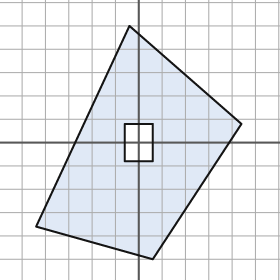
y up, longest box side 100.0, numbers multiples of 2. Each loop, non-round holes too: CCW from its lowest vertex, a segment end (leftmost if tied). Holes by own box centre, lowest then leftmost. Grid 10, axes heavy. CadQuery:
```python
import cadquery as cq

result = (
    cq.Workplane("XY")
    .moveTo(6.0, -50.0)
    .lineTo(44.0, 8.0)
    .lineTo(-4.0, 50.0)
    .lineTo(-44.0, -36.0)
    .close()
    .moveTo(-6.0, -8.0)
    .lineTo(6.0, -8.0)
    .lineTo(6.0, 8.0)
    .lineTo(-6.0, 8.0)
    .close()
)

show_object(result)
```